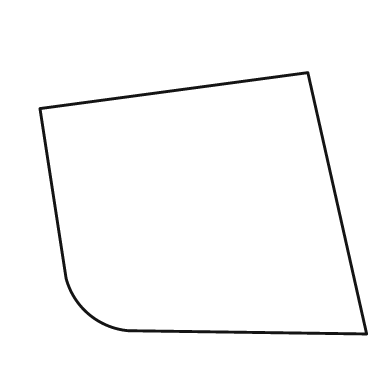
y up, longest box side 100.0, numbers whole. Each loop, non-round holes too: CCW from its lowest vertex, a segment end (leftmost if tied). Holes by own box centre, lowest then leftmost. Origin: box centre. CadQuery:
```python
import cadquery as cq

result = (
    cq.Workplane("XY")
    .moveTo(50.0, -40.0)
    .lineTo(32.0, 40.0)
    .lineTo(-50.0, 29.0)
    .lineTo(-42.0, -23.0)
    .threePointArc((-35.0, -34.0), (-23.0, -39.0))
    .close()
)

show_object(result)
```